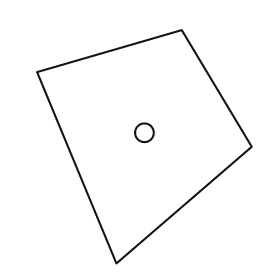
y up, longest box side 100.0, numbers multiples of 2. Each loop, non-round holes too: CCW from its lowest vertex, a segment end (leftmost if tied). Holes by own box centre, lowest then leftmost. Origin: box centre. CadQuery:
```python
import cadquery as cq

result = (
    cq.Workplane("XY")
    .moveTo(-12.0, -50.0)
    .lineTo(46.0, 0.0)
    .lineTo(16.0, 50.0)
    .lineTo(-46.0, 32.0)
    .close()
    .moveTo(0.0, 6.0)
    .circle(4.0)
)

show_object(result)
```